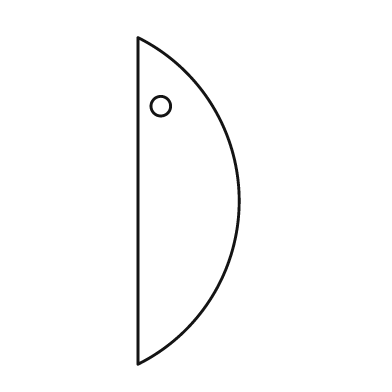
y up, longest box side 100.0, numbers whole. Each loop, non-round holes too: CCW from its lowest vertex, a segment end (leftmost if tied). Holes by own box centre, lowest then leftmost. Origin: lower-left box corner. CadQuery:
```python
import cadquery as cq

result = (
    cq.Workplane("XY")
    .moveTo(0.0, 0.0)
    .threePointArc((31.0, 50.0), (0.0, 100.0))
    .close()
    .moveTo(7.0, 79.0)
    .circle(3.0)
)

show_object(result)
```